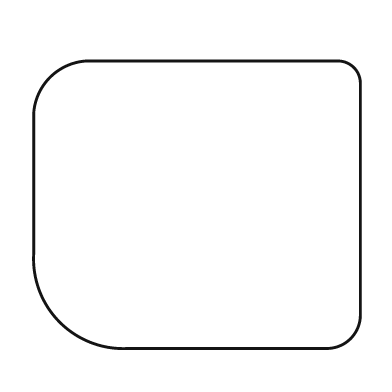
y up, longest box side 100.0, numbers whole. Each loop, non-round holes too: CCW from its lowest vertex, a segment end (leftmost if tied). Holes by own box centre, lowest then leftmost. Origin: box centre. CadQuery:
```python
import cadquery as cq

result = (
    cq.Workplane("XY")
    .moveTo(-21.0, -44.0)
    .lineTo(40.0, -44.0)
    .threePointArc((47.0, -41.0), (50.0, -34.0))
    .lineTo(50.0, 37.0)
    .threePointArc((48.0, 42.0), (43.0, 44.0))
    .lineTo(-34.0, 44.0)
    .threePointArc((-45.0, 39.0), (-50.0, 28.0))
    .lineTo(-50.0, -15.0)
    .threePointArc((-42.0, -36.0), (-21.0, -44.0))
    .close()
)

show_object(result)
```